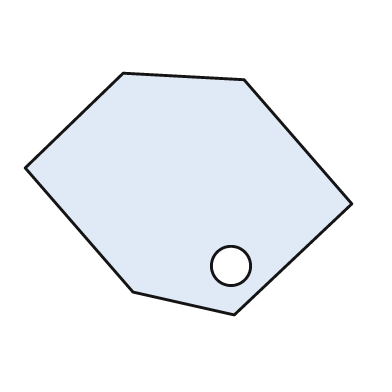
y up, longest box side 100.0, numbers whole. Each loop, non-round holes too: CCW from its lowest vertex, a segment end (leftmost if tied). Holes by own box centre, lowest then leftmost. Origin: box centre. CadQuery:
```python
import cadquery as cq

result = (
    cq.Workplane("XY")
    .moveTo(14.0, -37.0)
    .lineTo(50.0, -3.0)
    .lineTo(17.0, 35.0)
    .lineTo(-20.0, 37.0)
    .lineTo(-50.0, 8.0)
    .lineTo(-17.0, -30.0)
    .close()
    .moveTo(13.0, -22.0)
    .circle(6.0)
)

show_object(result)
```